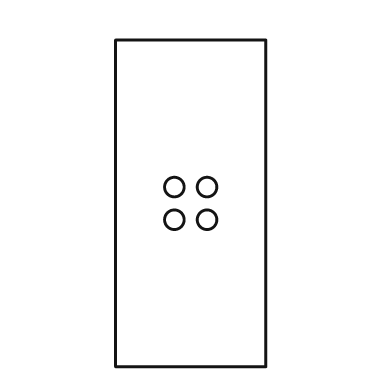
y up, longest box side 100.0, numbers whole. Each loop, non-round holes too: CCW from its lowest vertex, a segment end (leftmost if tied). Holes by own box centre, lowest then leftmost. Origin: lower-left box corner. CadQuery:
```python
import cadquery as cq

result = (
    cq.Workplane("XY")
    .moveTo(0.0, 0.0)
    .lineTo(46.0, 0.0)
    .lineTo(46.0, 100.0)
    .lineTo(0.0, 100.0)
    .close()
    .moveTo(18.0, 45.0)
    .circle(3.0)
    .moveTo(28.0, 45.0)
    .circle(3.0)
    .moveTo(18.0, 55.0)
    .circle(3.0)
    .moveTo(28.0, 55.0)
    .circle(3.0)
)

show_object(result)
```